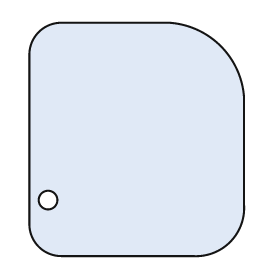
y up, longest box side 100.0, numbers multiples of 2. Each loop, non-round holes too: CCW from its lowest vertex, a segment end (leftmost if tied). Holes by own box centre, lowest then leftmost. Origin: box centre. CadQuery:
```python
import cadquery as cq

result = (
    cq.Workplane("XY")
    .moveTo(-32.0, -50.0)
    .lineTo(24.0, -50.0)
    .threePointArc((40.0, -44.0), (46.0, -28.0))
    .lineTo(46.0, 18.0)
    .threePointArc((36.0, 40.0), (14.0, 50.0))
    .lineTo(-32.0, 50.0)
    .threePointArc((-42.0, 46.0), (-46.0, 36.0))
    .lineTo(-46.0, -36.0)
    .threePointArc((-42.0, -46.0), (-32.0, -50.0))
    .close()
    .moveTo(-38.0, -26.0)
    .circle(4.0)
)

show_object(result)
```